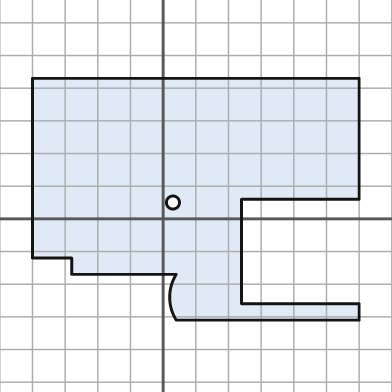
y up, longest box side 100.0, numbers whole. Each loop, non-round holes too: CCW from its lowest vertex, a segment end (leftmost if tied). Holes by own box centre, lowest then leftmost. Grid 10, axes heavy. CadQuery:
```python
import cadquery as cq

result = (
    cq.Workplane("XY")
    .moveTo(4.0, -31.0)
    .lineTo(60.0, -31.0)
    .lineTo(60.0, -26.0)
    .lineTo(24.0, -26.0)
    .lineTo(24.0, 6.0)
    .lineTo(60.0, 6.0)
    .lineTo(60.0, 43.0)
    .lineTo(-40.0, 43.0)
    .lineTo(-40.0, -12.0)
    .lineTo(-28.0, -12.0)
    .lineTo(-28.0, -17.0)
    .lineTo(4.0, -17.0)
    .threePointArc((2.0, -24.0), (4.0, -31.0))
    .close()
    .moveTo(3.0, 5.0)
    .circle(2.0)
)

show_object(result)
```